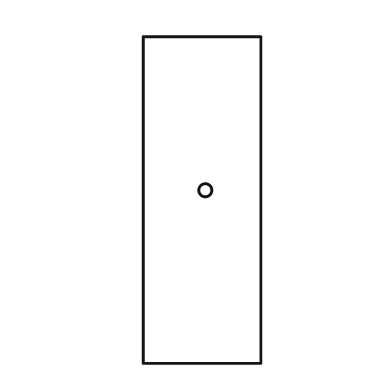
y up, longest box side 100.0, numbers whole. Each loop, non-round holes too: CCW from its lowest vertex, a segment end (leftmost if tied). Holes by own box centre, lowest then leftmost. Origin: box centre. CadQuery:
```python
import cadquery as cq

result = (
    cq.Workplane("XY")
    .moveTo(-18.0, -50.0)
    .lineTo(18.0, -50.0)
    .lineTo(18.0, 50.0)
    .lineTo(-18.0, 50.0)
    .close()
    .moveTo(1.0, 3.0)
    .circle(2.0)
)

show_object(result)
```